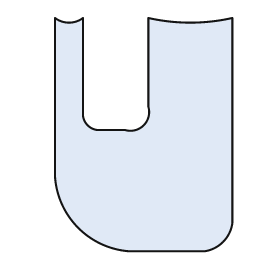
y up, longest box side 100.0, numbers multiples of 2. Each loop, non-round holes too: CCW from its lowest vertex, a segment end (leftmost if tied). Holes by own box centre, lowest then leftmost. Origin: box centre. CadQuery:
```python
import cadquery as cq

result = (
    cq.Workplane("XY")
    .moveTo(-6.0, -50.0)
    .lineTo(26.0, -50.0)
    .threePointArc((34.0, -46.0), (38.0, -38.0))
    .lineTo(38.0, 50.0)
    .threePointArc((20.0, 48.0), (2.0, 50.0))
    .lineTo(2.0, 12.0)
    .threePointArc((0.0, 4.0), (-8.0, 2.0))
    .lineTo(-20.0, 2.0)
    .threePointArc((-24.0, 4.0), (-26.0, 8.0))
    .lineTo(-26.0, 50.0)
    .threePointArc((-32.0, 48.0), (-38.0, 50.0))
    .lineTo(-38.0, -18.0)
    .threePointArc((-28.0, -40.0), (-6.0, -50.0))
    .close()
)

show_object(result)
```